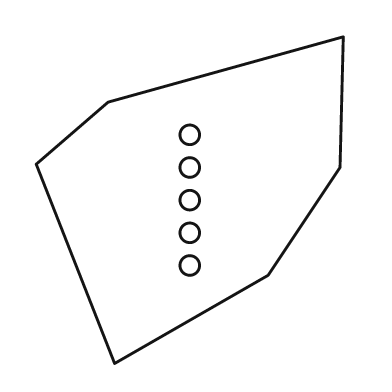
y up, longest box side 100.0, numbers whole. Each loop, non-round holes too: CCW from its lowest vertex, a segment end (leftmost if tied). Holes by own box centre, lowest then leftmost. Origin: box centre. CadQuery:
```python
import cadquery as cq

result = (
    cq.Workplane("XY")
    .moveTo(-23.0, -50.0)
    .lineTo(24.0, -23.0)
    .lineTo(46.0, 10.0)
    .lineTo(47.0, 50.0)
    .lineTo(-25.0, 30.0)
    .lineTo(-47.0, 11.0)
    .close()
    .moveTo(0.0, -20.0)
    .circle(3.0)
    .moveTo(0.0, -10.0)
    .circle(3.0)
    .moveTo(0.0, 0.0)
    .circle(3.0)
    .moveTo(0.0, 10.0)
    .circle(3.0)
    .moveTo(0.0, 20.0)
    .circle(3.0)
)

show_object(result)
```